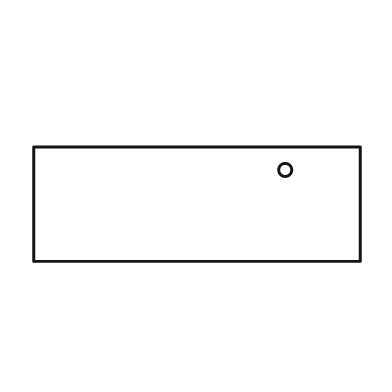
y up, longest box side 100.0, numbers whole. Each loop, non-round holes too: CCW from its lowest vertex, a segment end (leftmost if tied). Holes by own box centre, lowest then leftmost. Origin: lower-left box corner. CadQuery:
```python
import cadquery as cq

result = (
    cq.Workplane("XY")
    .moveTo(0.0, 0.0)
    .lineTo(100.0, 0.0)
    .lineTo(100.0, 35.0)
    .lineTo(0.0, 35.0)
    .close()
    .moveTo(77.0, 28.0)
    .circle(2.0)
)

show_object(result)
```